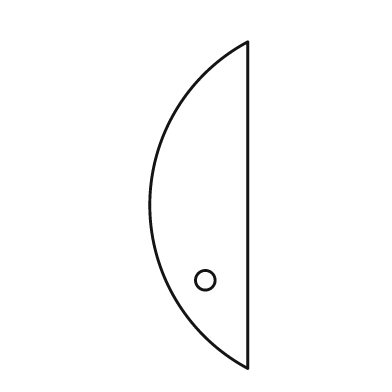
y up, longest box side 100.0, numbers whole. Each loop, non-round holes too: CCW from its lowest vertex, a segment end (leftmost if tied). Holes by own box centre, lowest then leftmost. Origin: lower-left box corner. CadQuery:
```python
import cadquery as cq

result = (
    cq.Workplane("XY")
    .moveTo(30.0, 0.0)
    .lineTo(30.0, 100.0)
    .threePointArc((0.0, 50.0), (30.0, 0.0))
    .close()
    .moveTo(17.0, 27.0)
    .circle(3.0)
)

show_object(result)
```